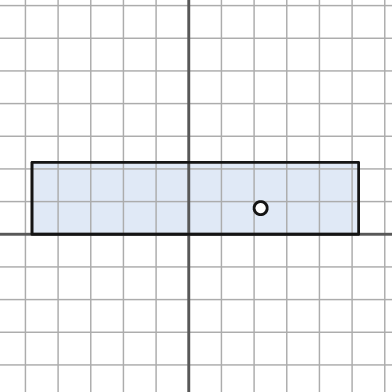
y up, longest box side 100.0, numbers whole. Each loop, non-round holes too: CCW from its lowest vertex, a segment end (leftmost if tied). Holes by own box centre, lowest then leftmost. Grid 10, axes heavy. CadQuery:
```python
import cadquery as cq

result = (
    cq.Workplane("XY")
    .moveTo(-48.0, 0.0)
    .lineTo(52.0, 0.0)
    .lineTo(52.0, 22.0)
    .lineTo(-48.0, 22.0)
    .close()
    .moveTo(22.0, 8.0)
    .circle(2.0)
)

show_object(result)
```